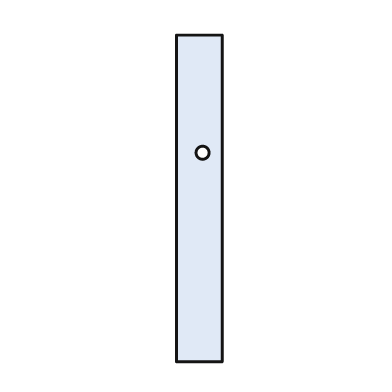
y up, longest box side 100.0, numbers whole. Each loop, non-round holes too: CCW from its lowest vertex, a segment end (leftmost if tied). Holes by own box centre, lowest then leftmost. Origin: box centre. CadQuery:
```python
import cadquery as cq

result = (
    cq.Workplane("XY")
    .moveTo(-7.0, -50.0)
    .lineTo(7.0, -50.0)
    .lineTo(7.0, 50.0)
    .lineTo(-7.0, 50.0)
    .close()
    .moveTo(1.0, 14.0)
    .circle(2.0)
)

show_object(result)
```